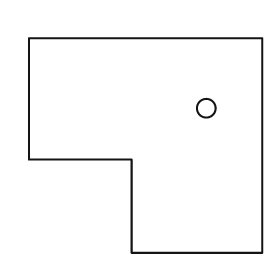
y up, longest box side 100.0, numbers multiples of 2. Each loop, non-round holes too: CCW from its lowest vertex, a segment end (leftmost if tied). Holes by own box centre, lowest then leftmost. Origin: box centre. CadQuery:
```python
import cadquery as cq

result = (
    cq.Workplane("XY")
    .moveTo(-6.0, -46.0)
    .lineTo(50.0, -46.0)
    .lineTo(50.0, 46.0)
    .lineTo(-50.0, 46.0)
    .lineTo(-50.0, -6.0)
    .lineTo(-6.0, -6.0)
    .close()
    .moveTo(26.0, 16.0)
    .circle(4.0)
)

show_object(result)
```